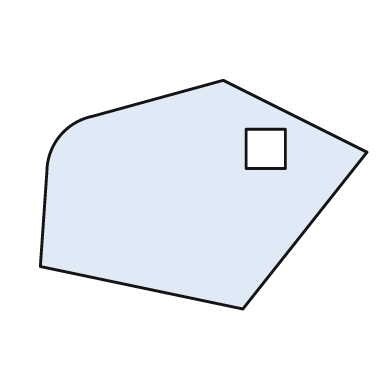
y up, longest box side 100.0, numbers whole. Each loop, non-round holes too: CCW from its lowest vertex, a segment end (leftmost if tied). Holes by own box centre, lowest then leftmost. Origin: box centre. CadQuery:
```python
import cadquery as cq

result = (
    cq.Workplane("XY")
    .moveTo(12.0, -35.0)
    .lineTo(50.0, 13.0)
    .lineTo(6.0, 35.0)
    .lineTo(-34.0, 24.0)
    .threePointArc((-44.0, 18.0), (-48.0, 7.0))
    .lineTo(-50.0, -22.0)
    .close()
    .moveTo(13.0, 8.0)
    .lineTo(25.0, 8.0)
    .lineTo(25.0, 20.0)
    .lineTo(13.0, 20.0)
    .close()
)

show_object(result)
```